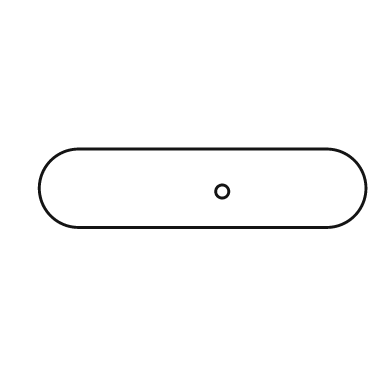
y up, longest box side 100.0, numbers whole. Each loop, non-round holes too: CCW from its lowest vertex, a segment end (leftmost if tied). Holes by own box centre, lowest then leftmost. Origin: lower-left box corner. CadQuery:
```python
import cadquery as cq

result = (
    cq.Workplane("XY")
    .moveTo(12.0, 0.0)
    .lineTo(88.0, 0.0)
    .threePointArc((100.0, 12.0), (88.0, 24.0))
    .lineTo(12.0, 24.0)
    .threePointArc((0.0, 12.0), (12.0, 0.0))
    .close()
    .moveTo(56.0, 11.0)
    .circle(2.0)
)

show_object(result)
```